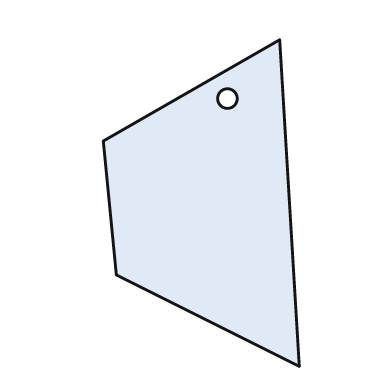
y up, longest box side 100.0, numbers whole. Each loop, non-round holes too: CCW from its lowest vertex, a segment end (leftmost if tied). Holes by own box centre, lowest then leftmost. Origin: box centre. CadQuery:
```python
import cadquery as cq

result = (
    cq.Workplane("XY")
    .moveTo(30.0, -50.0)
    .lineTo(24.0, 50.0)
    .lineTo(-30.0, 19.0)
    .lineTo(-26.0, -22.0)
    .close()
    .moveTo(8.0, 32.0)
    .circle(3.0)
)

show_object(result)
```